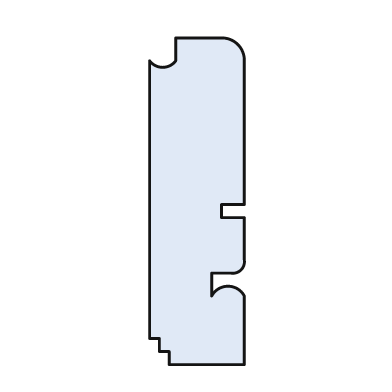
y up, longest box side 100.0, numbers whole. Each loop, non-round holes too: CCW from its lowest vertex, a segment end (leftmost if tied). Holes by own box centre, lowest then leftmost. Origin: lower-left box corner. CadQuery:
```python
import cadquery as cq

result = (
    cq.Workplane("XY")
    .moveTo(6.0, 0.0)
    .lineTo(29.0, 0.0)
    .lineTo(29.0, 21.0)
    .threePointArc((24.0, 24.0), (19.0, 21.0))
    .lineTo(19.0, 28.0)
    .lineTo(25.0, 28.0)
    .threePointArc((28.0, 29.0), (29.0, 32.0))
    .lineTo(29.0, 45.0)
    .lineTo(22.0, 45.0)
    .lineTo(22.0, 49.0)
    .lineTo(29.0, 49.0)
    .lineTo(29.0, 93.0)
    .threePointArc((27.0, 98.0), (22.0, 100.0))
    .lineTo(8.0, 100.0)
    .lineTo(8.0, 93.0)
    .threePointArc((4.0, 91.0), (0.0, 93.0))
    .lineTo(0.0, 8.0)
    .lineTo(3.0, 8.0)
    .lineTo(3.0, 4.0)
    .lineTo(6.0, 4.0)
    .close()
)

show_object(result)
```